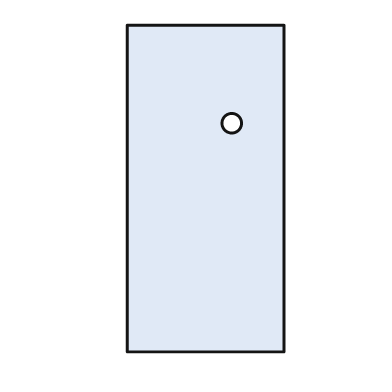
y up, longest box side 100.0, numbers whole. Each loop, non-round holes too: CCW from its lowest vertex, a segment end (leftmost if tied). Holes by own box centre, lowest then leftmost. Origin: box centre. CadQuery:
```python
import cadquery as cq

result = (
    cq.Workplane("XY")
    .moveTo(-24.0, -50.0)
    .lineTo(24.0, -50.0)
    .lineTo(24.0, 50.0)
    .lineTo(-24.0, 50.0)
    .close()
    .moveTo(8.0, 20.0)
    .circle(3.0)
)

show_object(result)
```